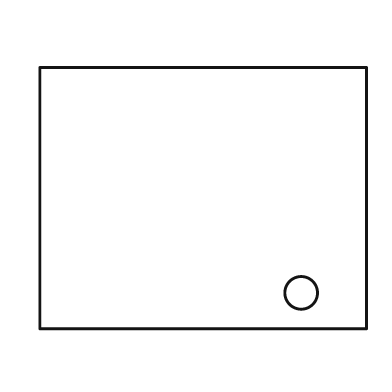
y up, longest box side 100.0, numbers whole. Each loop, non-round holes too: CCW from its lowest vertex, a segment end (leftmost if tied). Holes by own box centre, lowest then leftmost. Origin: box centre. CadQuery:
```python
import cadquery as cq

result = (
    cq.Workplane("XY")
    .moveTo(-50.0, -40.0)
    .lineTo(50.0, -40.0)
    .lineTo(50.0, 40.0)
    .lineTo(-50.0, 40.0)
    .close()
    .moveTo(30.0, -29.0)
    .circle(5.0)
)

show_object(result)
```